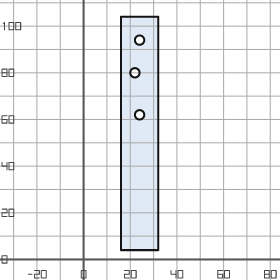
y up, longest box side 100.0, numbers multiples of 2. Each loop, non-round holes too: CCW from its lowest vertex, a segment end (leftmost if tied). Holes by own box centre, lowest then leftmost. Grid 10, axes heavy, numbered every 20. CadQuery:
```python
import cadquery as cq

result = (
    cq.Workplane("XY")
    .moveTo(16.0, 4.0)
    .lineTo(32.0, 4.0)
    .lineTo(32.0, 104.0)
    .lineTo(16.0, 104.0)
    .close()
    .moveTo(24.0, 62.0)
    .circle(2.0)
    .moveTo(22.0, 80.0)
    .circle(2.0)
    .moveTo(24.0, 94.0)
    .circle(2.0)
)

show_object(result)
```